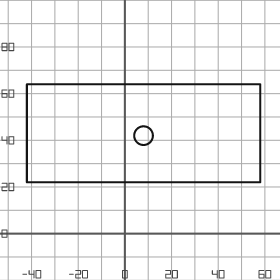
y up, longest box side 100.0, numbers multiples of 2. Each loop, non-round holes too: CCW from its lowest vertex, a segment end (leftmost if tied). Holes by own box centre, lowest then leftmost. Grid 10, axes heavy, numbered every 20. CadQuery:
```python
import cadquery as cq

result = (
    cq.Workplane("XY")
    .moveTo(-42.0, 22.0)
    .lineTo(58.0, 22.0)
    .lineTo(58.0, 64.0)
    .lineTo(-42.0, 64.0)
    .close()
    .moveTo(8.0, 42.0)
    .circle(4.0)
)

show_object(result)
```